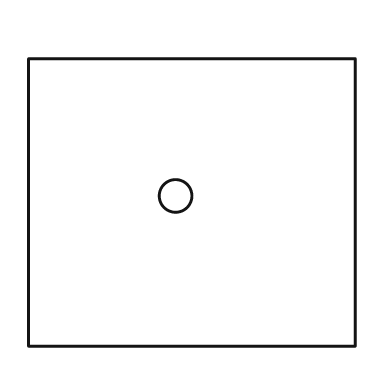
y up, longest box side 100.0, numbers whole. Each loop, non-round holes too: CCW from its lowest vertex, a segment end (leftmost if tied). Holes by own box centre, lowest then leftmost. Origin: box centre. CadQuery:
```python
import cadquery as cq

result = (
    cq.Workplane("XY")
    .moveTo(-50.0, -44.0)
    .lineTo(50.0, -44.0)
    .lineTo(50.0, 44.0)
    .lineTo(-50.0, 44.0)
    .close()
    .moveTo(-5.0, 2.0)
    .circle(5.0)
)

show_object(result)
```